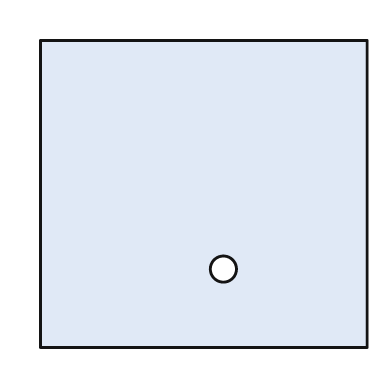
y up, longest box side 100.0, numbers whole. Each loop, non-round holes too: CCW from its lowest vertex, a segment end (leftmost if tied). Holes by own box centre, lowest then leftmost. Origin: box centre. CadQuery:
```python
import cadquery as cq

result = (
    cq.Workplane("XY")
    .moveTo(-50.0, -47.0)
    .lineTo(50.0, -47.0)
    .lineTo(50.0, 47.0)
    .lineTo(-50.0, 47.0)
    .close()
    .moveTo(6.0, -23.0)
    .circle(4.0)
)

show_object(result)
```